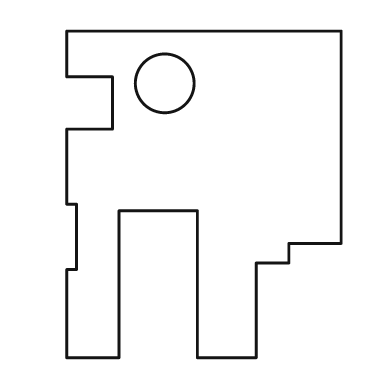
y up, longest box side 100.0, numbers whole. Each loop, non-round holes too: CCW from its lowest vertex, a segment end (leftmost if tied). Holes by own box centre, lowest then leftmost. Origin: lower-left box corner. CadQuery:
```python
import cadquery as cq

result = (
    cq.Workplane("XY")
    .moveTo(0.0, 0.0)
    .lineTo(16.0, 0.0)
    .lineTo(16.0, 45.0)
    .lineTo(40.0, 45.0)
    .lineTo(40.0, 0.0)
    .lineTo(58.0, 0.0)
    .lineTo(58.0, 29.0)
    .lineTo(68.0, 29.0)
    .lineTo(68.0, 35.0)
    .lineTo(84.0, 35.0)
    .lineTo(84.0, 100.0)
    .lineTo(0.0, 100.0)
    .lineTo(0.0, 86.0)
    .lineTo(14.0, 86.0)
    .lineTo(14.0, 70.0)
    .lineTo(0.0, 70.0)
    .lineTo(0.0, 47.0)
    .lineTo(3.0, 47.0)
    .lineTo(3.0, 27.0)
    .lineTo(0.0, 27.0)
    .close()
    .moveTo(30.0, 84.0)
    .circle(9.0)
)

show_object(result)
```